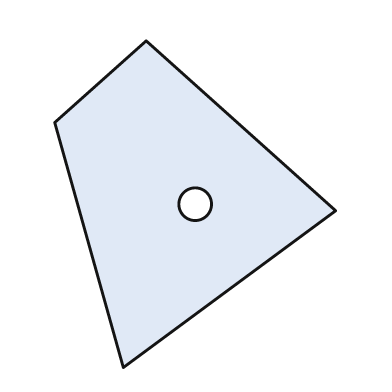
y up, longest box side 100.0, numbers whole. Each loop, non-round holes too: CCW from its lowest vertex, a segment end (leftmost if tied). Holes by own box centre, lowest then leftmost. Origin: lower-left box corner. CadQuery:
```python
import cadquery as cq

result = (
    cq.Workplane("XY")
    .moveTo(21.0, 0.0)
    .lineTo(86.0, 48.0)
    .lineTo(28.0, 100.0)
    .lineTo(0.0, 75.0)
    .close()
    .moveTo(43.0, 50.0)
    .circle(5.0)
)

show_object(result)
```